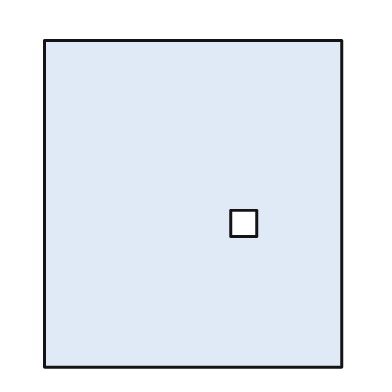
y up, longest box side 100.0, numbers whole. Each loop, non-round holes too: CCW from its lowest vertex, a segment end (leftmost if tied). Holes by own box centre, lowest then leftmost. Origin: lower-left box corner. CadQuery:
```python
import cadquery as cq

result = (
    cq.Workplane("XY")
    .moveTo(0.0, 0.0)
    .lineTo(91.0, 0.0)
    .lineTo(91.0, 100.0)
    .lineTo(0.0, 100.0)
    .close()
    .moveTo(57.0, 40.0)
    .lineTo(65.0, 40.0)
    .lineTo(65.0, 48.0)
    .lineTo(57.0, 48.0)
    .close()
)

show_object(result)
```